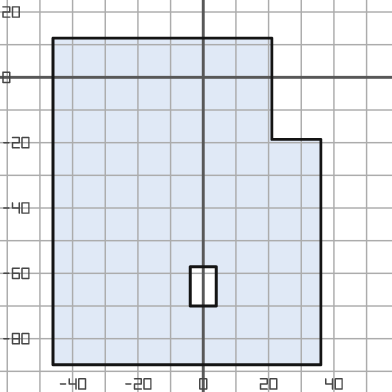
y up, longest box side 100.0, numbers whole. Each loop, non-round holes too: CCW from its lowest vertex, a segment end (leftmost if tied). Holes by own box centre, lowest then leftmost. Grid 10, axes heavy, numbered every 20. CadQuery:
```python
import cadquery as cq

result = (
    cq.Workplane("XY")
    .moveTo(-46.0, -88.0)
    .lineTo(36.0, -88.0)
    .lineTo(36.0, -19.0)
    .lineTo(21.0, -19.0)
    .lineTo(21.0, 12.0)
    .lineTo(-46.0, 12.0)
    .close()
    .moveTo(-4.0, -70.0)
    .lineTo(4.0, -70.0)
    .lineTo(4.0, -58.0)
    .lineTo(-4.0, -58.0)
    .close()
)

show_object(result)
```